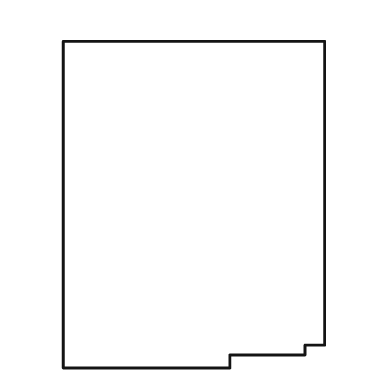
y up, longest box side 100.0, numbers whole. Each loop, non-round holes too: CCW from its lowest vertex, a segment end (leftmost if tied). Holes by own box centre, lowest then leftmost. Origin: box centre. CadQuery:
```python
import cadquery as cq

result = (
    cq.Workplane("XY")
    .moveTo(-40.0, -50.0)
    .lineTo(11.0, -50.0)
    .lineTo(11.0, -46.0)
    .lineTo(34.0, -46.0)
    .lineTo(34.0, -43.0)
    .lineTo(40.0, -43.0)
    .lineTo(40.0, 50.0)
    .lineTo(-40.0, 50.0)
    .close()
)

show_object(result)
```